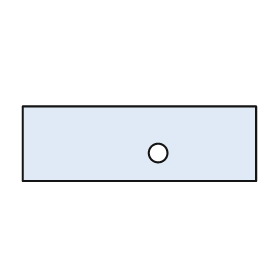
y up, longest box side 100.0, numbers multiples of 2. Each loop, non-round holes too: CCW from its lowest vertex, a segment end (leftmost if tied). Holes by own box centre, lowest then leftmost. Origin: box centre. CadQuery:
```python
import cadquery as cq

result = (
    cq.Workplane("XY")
    .moveTo(-50.0, -16.0)
    .lineTo(50.0, -16.0)
    .lineTo(50.0, 16.0)
    .lineTo(-50.0, 16.0)
    .close()
    .moveTo(8.0, -4.0)
    .circle(4.0)
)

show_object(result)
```